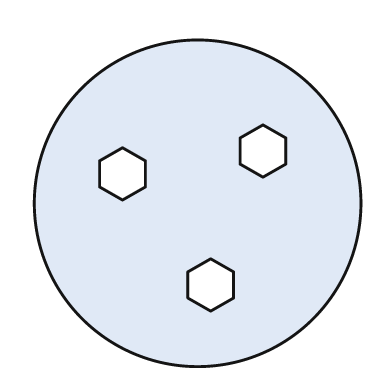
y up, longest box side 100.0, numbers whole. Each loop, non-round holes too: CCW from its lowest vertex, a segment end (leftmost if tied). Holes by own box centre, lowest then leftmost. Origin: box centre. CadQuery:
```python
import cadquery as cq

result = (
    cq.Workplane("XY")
    .moveTo(0.0, 0.0)
    .circle(50.0)
    .moveTo(4.0, -33.0)
    .lineTo(11.0, -29.0)
    .lineTo(11.0, -21.0)
    .lineTo(4.0, -17.0)
    .lineTo(-3.0, -21.0)
    .lineTo(-3.0, -29.0)
    .close()
    .moveTo(-23.0, 1.0)
    .lineTo(-16.0, 5.0)
    .lineTo(-16.0, 13.0)
    .lineTo(-23.0, 17.0)
    .lineTo(-30.0, 13.0)
    .lineTo(-30.0, 5.0)
    .close()
    .moveTo(20.0, 8.0)
    .lineTo(27.0, 12.0)
    .lineTo(27.0, 20.0)
    .lineTo(20.0, 24.0)
    .lineTo(13.0, 20.0)
    .lineTo(13.0, 12.0)
    .close()
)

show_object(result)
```